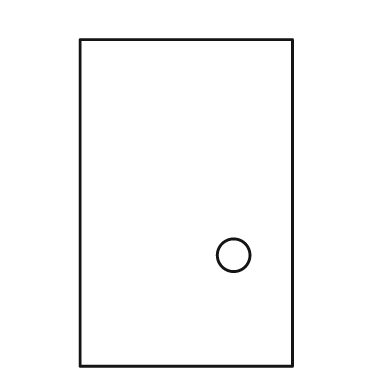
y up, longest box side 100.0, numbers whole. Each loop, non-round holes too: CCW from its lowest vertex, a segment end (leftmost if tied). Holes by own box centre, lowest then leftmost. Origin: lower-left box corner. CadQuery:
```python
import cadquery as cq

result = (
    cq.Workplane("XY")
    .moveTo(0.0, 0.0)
    .lineTo(65.0, 0.0)
    .lineTo(65.0, 100.0)
    .lineTo(0.0, 100.0)
    .close()
    .moveTo(47.0, 34.0)
    .circle(5.0)
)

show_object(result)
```